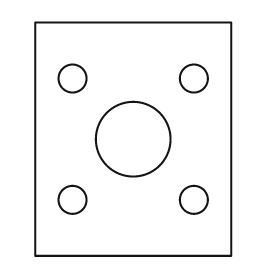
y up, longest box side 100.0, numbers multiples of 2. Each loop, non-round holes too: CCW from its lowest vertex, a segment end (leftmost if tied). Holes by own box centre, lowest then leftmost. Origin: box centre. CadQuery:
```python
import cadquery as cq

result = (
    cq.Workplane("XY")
    .moveTo(-42.0, -50.0)
    .lineTo(42.0, -50.0)
    .lineTo(42.0, 50.0)
    .lineTo(-42.0, 50.0)
    .close()
    .moveTo(-26.0, -26.0)
    .circle(6.0)
    .moveTo(26.0, -26.0)
    .circle(6.0)
    .moveTo(0.0, 0.0)
    .circle(16.0)
    .moveTo(-26.0, 26.0)
    .circle(6.0)
    .moveTo(26.0, 26.0)
    .circle(6.0)
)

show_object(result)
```